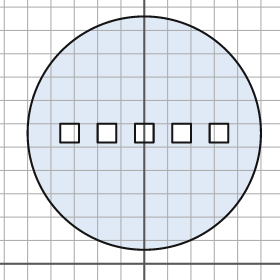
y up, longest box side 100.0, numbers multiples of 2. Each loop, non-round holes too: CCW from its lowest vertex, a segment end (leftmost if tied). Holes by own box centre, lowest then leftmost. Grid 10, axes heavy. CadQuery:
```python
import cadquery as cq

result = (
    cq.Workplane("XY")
    .moveTo(0.0, 56.0)
    .circle(50.0)
    .moveTo(-36.0, 52.0)
    .lineTo(-28.0, 52.0)
    .lineTo(-28.0, 60.0)
    .lineTo(-36.0, 60.0)
    .close()
    .moveTo(-20.0, 52.0)
    .lineTo(-12.0, 52.0)
    .lineTo(-12.0, 60.0)
    .lineTo(-20.0, 60.0)
    .close()
    .moveTo(-4.0, 52.0)
    .lineTo(4.0, 52.0)
    .lineTo(4.0, 60.0)
    .lineTo(-4.0, 60.0)
    .close()
    .moveTo(12.0, 52.0)
    .lineTo(20.0, 52.0)
    .lineTo(20.0, 60.0)
    .lineTo(12.0, 60.0)
    .close()
    .moveTo(28.0, 52.0)
    .lineTo(36.0, 52.0)
    .lineTo(36.0, 60.0)
    .lineTo(28.0, 60.0)
    .close()
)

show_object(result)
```